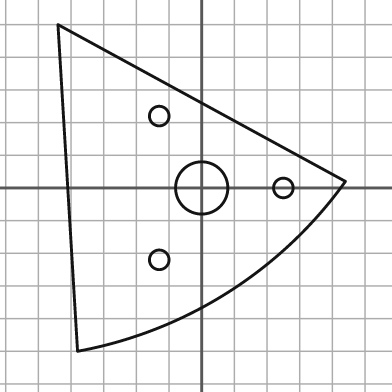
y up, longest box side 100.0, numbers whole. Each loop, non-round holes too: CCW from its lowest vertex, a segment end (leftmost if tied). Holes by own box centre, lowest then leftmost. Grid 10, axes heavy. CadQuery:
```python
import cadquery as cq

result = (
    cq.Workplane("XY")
    .moveTo(-38.0, -50.0)
    .threePointArc((8.0, -32.0), (44.0, 2.0))
    .lineTo(-44.0, 50.0)
    .close()
    .moveTo(-13.0, -22.0)
    .circle(3.0)
    .moveTo(0.0, 0.0)
    .circle(8.0)
    .moveTo(25.0, 0.0)
    .circle(3.0)
    .moveTo(-13.0, 22.0)
    .circle(3.0)
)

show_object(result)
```